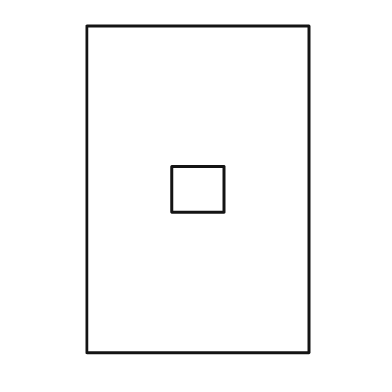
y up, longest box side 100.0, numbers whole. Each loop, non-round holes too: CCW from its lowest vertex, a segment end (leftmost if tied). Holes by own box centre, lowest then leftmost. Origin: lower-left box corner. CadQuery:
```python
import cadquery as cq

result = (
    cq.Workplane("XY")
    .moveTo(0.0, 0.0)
    .lineTo(68.0, 0.0)
    .lineTo(68.0, 100.0)
    .lineTo(0.0, 100.0)
    .close()
    .moveTo(26.0, 43.0)
    .lineTo(42.0, 43.0)
    .lineTo(42.0, 57.0)
    .lineTo(26.0, 57.0)
    .close()
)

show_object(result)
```